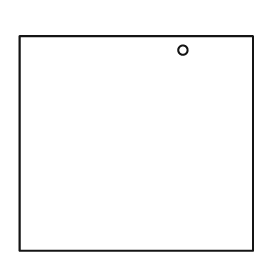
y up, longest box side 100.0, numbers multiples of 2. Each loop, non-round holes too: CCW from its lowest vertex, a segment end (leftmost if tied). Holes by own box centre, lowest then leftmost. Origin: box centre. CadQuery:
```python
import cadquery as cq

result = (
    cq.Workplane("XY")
    .moveTo(-50.0, -46.0)
    .lineTo(50.0, -46.0)
    .lineTo(50.0, 46.0)
    .lineTo(-50.0, 46.0)
    .close()
    .moveTo(20.0, 40.0)
    .circle(2.0)
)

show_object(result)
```